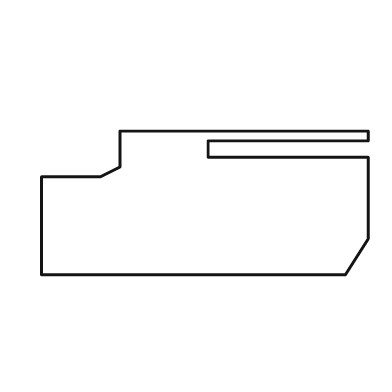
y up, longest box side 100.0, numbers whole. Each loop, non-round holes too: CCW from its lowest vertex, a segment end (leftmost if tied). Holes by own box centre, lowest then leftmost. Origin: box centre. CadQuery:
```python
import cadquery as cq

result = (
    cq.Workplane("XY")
    .moveTo(-50.0, -22.0)
    .lineTo(43.0, -22.0)
    .lineTo(50.0, -11.0)
    .lineTo(50.0, 14.0)
    .lineTo(1.0, 14.0)
    .lineTo(1.0, 19.0)
    .lineTo(50.0, 19.0)
    .lineTo(50.0, 22.0)
    .lineTo(-26.0, 22.0)
    .lineTo(-26.0, 11.0)
    .lineTo(-32.0, 8.0)
    .lineTo(-50.0, 8.0)
    .close()
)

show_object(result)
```